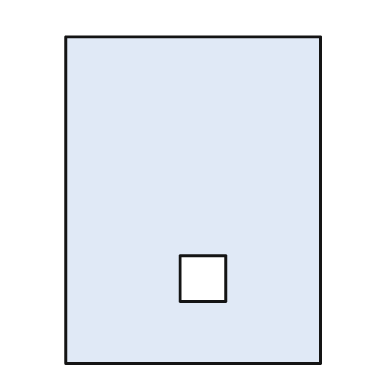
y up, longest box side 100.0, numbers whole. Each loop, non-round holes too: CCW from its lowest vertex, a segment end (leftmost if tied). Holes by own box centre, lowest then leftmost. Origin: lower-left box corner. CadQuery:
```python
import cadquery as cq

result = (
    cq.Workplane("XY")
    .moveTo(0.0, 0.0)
    .lineTo(78.0, 0.0)
    .lineTo(78.0, 100.0)
    .lineTo(0.0, 100.0)
    .close()
    .moveTo(35.0, 19.0)
    .lineTo(49.0, 19.0)
    .lineTo(49.0, 33.0)
    .lineTo(35.0, 33.0)
    .close()
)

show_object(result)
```